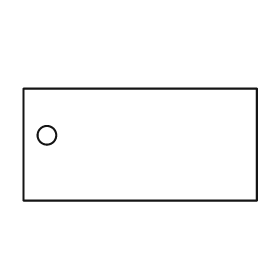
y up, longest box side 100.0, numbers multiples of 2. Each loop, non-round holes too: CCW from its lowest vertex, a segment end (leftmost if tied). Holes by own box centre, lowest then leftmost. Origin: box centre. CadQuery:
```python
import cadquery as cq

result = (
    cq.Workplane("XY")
    .moveTo(-50.0, -24.0)
    .lineTo(50.0, -24.0)
    .lineTo(50.0, 24.0)
    .lineTo(-50.0, 24.0)
    .close()
    .moveTo(-40.0, 4.0)
    .circle(4.0)
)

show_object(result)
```